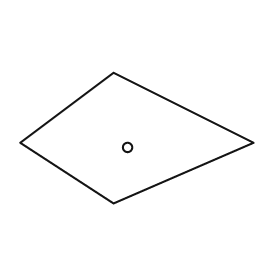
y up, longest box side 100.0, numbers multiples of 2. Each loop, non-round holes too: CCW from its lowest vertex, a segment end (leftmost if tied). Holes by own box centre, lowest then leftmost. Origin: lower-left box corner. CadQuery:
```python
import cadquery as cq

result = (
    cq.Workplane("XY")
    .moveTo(40.0, 0.0)
    .lineTo(100.0, 26.0)
    .lineTo(40.0, 56.0)
    .lineTo(0.0, 26.0)
    .close()
    .moveTo(46.0, 24.0)
    .circle(2.0)
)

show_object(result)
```